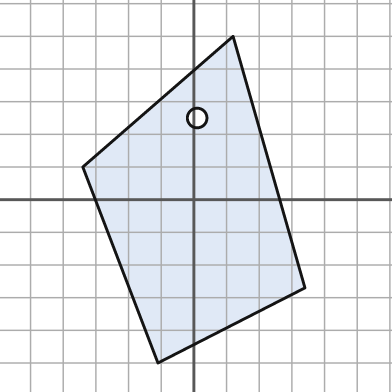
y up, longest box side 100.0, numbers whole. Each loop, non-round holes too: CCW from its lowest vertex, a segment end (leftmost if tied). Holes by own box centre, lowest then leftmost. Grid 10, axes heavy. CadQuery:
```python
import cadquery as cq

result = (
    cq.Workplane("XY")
    .moveTo(-11.0, -50.0)
    .lineTo(34.0, -27.0)
    .lineTo(12.0, 50.0)
    .lineTo(-34.0, 10.0)
    .close()
    .moveTo(1.0, 25.0)
    .circle(3.0)
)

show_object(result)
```